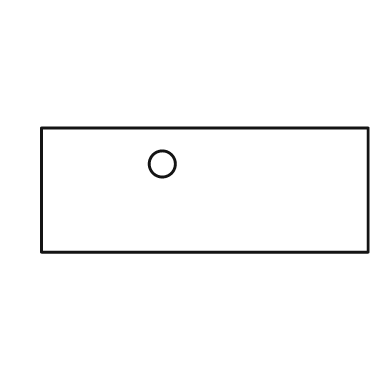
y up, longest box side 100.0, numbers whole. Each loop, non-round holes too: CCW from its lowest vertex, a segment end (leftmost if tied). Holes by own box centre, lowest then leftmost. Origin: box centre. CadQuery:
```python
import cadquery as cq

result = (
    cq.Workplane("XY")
    .moveTo(-50.0, -19.0)
    .lineTo(50.0, -19.0)
    .lineTo(50.0, 19.0)
    .lineTo(-50.0, 19.0)
    .close()
    .moveTo(-13.0, 8.0)
    .circle(4.0)
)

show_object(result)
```